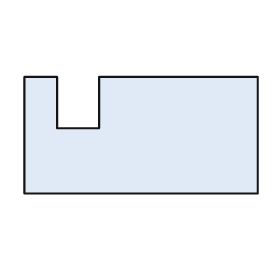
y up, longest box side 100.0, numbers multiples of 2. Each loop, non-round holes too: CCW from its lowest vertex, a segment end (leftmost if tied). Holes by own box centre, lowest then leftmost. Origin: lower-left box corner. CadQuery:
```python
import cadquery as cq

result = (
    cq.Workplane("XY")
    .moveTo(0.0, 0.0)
    .lineTo(100.0, 0.0)
    .lineTo(100.0, 50.0)
    .lineTo(32.0, 50.0)
    .lineTo(32.0, 28.0)
    .lineTo(14.0, 28.0)
    .lineTo(14.0, 50.0)
    .lineTo(0.0, 50.0)
    .close()
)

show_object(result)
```